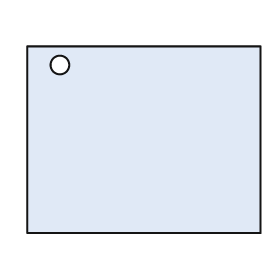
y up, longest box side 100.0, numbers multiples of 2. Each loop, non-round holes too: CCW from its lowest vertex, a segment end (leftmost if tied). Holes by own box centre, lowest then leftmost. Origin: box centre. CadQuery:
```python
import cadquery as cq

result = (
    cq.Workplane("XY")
    .moveTo(-50.0, -40.0)
    .lineTo(50.0, -40.0)
    .lineTo(50.0, 40.0)
    .lineTo(-50.0, 40.0)
    .close()
    .moveTo(-36.0, 32.0)
    .circle(4.0)
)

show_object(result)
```